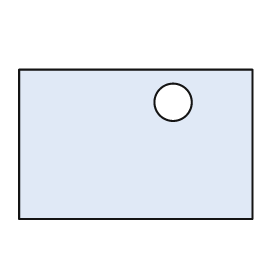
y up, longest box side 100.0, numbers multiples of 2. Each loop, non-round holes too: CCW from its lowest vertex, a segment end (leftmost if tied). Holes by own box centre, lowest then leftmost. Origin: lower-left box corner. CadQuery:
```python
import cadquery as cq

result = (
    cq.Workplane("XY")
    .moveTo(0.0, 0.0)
    .lineTo(100.0, 0.0)
    .lineTo(100.0, 64.0)
    .lineTo(0.0, 64.0)
    .close()
    .moveTo(66.0, 50.0)
    .circle(8.0)
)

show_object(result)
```